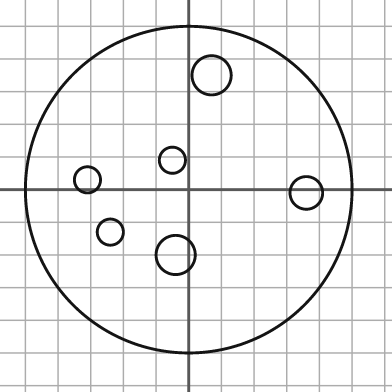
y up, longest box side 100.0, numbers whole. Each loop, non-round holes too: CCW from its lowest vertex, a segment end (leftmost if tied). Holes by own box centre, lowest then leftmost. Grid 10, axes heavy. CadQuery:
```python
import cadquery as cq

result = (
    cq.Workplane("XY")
    .moveTo(0.0, 0.0)
    .circle(50.0)
    .moveTo(-4.0, -20.0)
    .circle(6.0)
    .moveTo(-24.0, -13.0)
    .circle(4.0)
    .moveTo(36.0, -1.0)
    .circle(5.0)
    .moveTo(-31.0, 3.0)
    .circle(4.0)
    .moveTo(-5.0, 9.0)
    .circle(4.0)
    .moveTo(7.0, 35.0)
    .circle(6.0)
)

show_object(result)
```